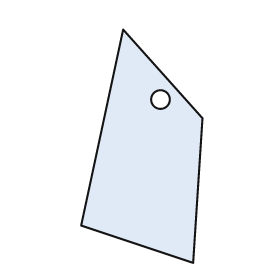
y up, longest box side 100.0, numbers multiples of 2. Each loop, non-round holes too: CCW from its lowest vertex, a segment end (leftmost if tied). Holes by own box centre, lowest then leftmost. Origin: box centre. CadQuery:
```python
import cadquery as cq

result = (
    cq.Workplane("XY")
    .moveTo(22.0, -50.0)
    .lineTo(26.0, 12.0)
    .lineTo(-8.0, 50.0)
    .lineTo(-26.0, -34.0)
    .close()
    .moveTo(8.0, 20.0)
    .circle(4.0)
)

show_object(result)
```